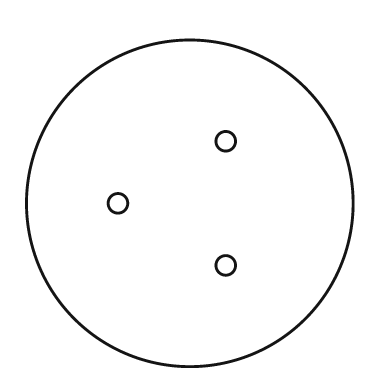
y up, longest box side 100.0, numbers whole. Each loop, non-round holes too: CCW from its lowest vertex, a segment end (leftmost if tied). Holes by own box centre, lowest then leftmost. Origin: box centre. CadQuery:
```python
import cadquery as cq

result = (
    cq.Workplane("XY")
    .moveTo(0.0, 0.0)
    .circle(50.0)
    .moveTo(11.0, -19.0)
    .circle(3.0)
    .moveTo(-22.0, 0.0)
    .circle(3.0)
    .moveTo(11.0, 19.0)
    .circle(3.0)
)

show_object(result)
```